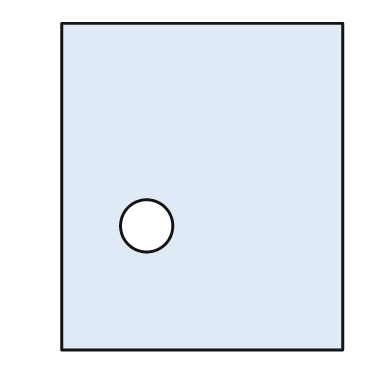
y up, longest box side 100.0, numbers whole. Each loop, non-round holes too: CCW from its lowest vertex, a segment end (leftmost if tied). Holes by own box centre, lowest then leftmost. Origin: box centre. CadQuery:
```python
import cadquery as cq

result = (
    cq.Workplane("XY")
    .moveTo(-43.0, -50.0)
    .lineTo(43.0, -50.0)
    .lineTo(43.0, 50.0)
    .lineTo(-43.0, 50.0)
    .close()
    .moveTo(-17.0, -12.0)
    .circle(8.0)
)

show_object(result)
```